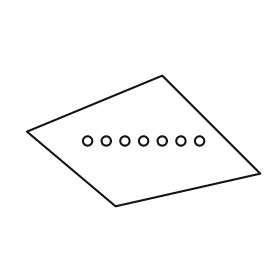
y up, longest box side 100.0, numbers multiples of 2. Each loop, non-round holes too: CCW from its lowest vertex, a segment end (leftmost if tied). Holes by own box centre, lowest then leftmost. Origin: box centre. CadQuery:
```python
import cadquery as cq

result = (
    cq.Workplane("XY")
    .moveTo(-12.0, -28.0)
    .lineTo(50.0, -14.0)
    .lineTo(8.0, 28.0)
    .lineTo(-50.0, 4.0)
    .close()
    .moveTo(-24.0, 0.0)
    .circle(2.0)
    .moveTo(-16.0, 0.0)
    .circle(2.0)
    .moveTo(-8.0, 0.0)
    .circle(2.0)
    .moveTo(0.0, 0.0)
    .circle(2.0)
    .moveTo(8.0, 0.0)
    .circle(2.0)
    .moveTo(16.0, 0.0)
    .circle(2.0)
    .moveTo(24.0, 0.0)
    .circle(2.0)
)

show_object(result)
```